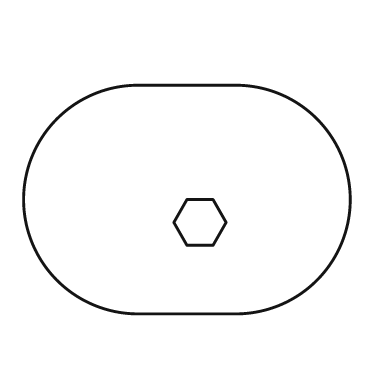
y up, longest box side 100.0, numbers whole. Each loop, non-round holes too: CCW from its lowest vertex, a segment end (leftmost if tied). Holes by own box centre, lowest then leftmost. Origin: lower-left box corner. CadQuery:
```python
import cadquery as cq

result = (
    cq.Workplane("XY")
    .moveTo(35.0, 0.0)
    .lineTo(65.0, 0.0)
    .threePointArc((100.0, 35.0), (65.0, 70.0))
    .lineTo(35.0, 70.0)
    .threePointArc((0.0, 35.0), (35.0, 0.0))
    .close()
    .moveTo(50.0, 21.0)
    .lineTo(58.0, 21.0)
    .lineTo(62.0, 28.0)
    .lineTo(58.0, 35.0)
    .lineTo(50.0, 35.0)
    .lineTo(46.0, 28.0)
    .close()
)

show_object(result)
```